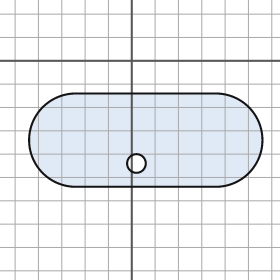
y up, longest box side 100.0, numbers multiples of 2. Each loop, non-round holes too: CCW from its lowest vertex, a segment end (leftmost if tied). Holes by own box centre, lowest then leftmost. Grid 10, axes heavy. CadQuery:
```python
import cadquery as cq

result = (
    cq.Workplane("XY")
    .moveTo(-24.0, -54.0)
    .lineTo(36.0, -54.0)
    .threePointArc((56.0, -34.0), (36.0, -14.0))
    .lineTo(-24.0, -14.0)
    .threePointArc((-44.0, -34.0), (-24.0, -54.0))
    .close()
    .moveTo(2.0, -44.0)
    .circle(4.0)
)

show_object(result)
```